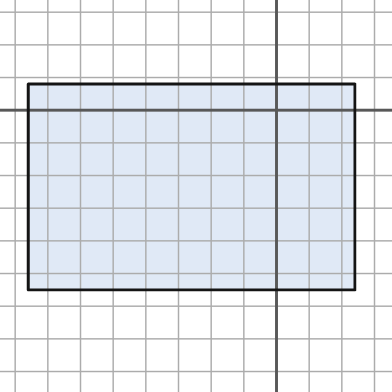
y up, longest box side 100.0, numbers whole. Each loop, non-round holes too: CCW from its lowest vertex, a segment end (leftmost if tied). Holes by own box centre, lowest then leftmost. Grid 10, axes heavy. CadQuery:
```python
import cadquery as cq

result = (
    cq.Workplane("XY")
    .moveTo(-76.0, -55.0)
    .lineTo(24.0, -55.0)
    .lineTo(24.0, 8.0)
    .lineTo(-76.0, 8.0)
    .close()
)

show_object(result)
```